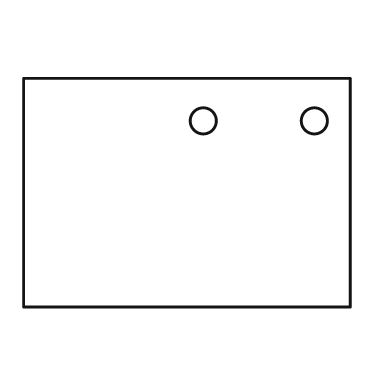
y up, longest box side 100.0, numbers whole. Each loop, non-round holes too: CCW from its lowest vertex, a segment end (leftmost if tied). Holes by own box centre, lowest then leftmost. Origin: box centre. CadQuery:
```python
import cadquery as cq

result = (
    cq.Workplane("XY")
    .moveTo(-50.0, -35.0)
    .lineTo(50.0, -35.0)
    .lineTo(50.0, 35.0)
    .lineTo(-50.0, 35.0)
    .close()
    .moveTo(5.0, 22.0)
    .circle(4.0)
    .moveTo(39.0, 22.0)
    .circle(4.0)
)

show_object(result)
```